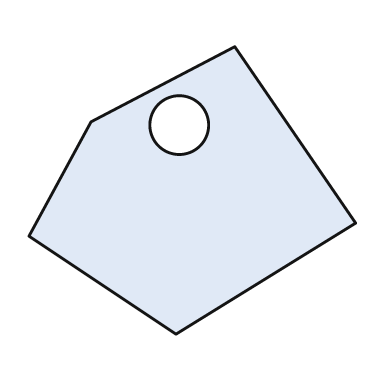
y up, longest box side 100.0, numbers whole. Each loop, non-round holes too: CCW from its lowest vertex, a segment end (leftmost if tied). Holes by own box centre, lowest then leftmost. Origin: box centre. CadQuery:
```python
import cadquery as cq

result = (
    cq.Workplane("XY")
    .moveTo(-5.0, -44.0)
    .lineTo(50.0, -10.0)
    .lineTo(13.0, 44.0)
    .lineTo(-31.0, 21.0)
    .lineTo(-50.0, -14.0)
    .close()
    .moveTo(-4.0, 20.0)
    .circle(9.0)
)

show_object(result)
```